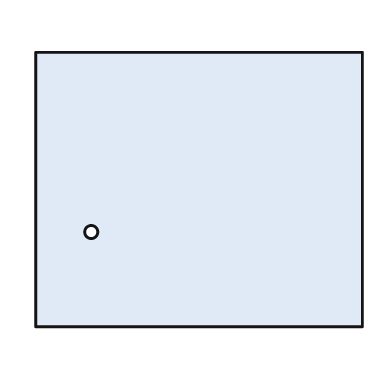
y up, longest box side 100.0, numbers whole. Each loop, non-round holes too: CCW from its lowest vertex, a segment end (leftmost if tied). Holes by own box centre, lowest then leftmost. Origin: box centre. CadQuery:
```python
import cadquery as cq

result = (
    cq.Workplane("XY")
    .moveTo(-50.0, -42.0)
    .lineTo(50.0, -42.0)
    .lineTo(50.0, 42.0)
    .lineTo(-50.0, 42.0)
    .close()
    .moveTo(-33.0, -13.0)
    .circle(2.0)
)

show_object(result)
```